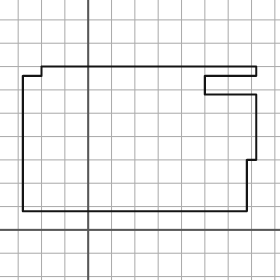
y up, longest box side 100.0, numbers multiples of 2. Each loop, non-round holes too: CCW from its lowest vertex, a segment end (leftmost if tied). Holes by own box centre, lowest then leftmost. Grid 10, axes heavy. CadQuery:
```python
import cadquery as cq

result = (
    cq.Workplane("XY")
    .moveTo(-28.0, 8.0)
    .lineTo(68.0, 8.0)
    .lineTo(68.0, 30.0)
    .lineTo(72.0, 30.0)
    .lineTo(72.0, 58.0)
    .lineTo(50.0, 58.0)
    .lineTo(50.0, 66.0)
    .lineTo(72.0, 66.0)
    .lineTo(72.0, 70.0)
    .lineTo(-20.0, 70.0)
    .lineTo(-20.0, 66.0)
    .lineTo(-28.0, 66.0)
    .close()
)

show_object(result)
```